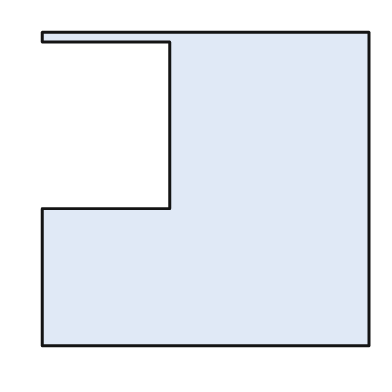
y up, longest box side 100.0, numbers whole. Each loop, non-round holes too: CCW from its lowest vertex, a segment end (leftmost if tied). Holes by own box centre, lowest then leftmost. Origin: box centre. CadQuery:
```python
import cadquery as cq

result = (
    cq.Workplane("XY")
    .moveTo(-50.0, -48.0)
    .lineTo(50.0, -48.0)
    .lineTo(50.0, 48.0)
    .lineTo(-50.0, 48.0)
    .lineTo(-50.0, 45.0)
    .lineTo(-11.0, 45.0)
    .lineTo(-11.0, -6.0)
    .lineTo(-50.0, -6.0)
    .close()
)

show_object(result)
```